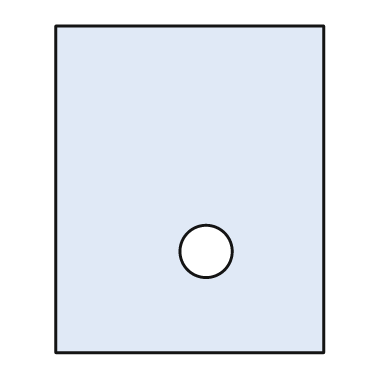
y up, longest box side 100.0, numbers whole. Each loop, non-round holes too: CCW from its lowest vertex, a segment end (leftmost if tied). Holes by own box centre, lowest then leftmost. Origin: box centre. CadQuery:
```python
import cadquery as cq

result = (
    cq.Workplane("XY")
    .moveTo(-41.0, -50.0)
    .lineTo(41.0, -50.0)
    .lineTo(41.0, 50.0)
    .lineTo(-41.0, 50.0)
    .close()
    .moveTo(5.0, -19.0)
    .circle(8.0)
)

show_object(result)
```